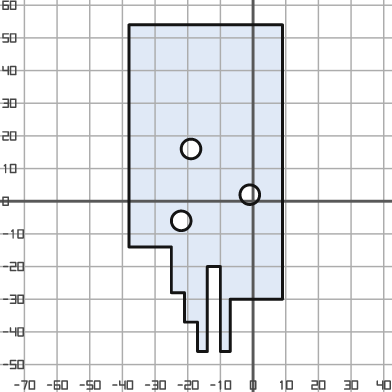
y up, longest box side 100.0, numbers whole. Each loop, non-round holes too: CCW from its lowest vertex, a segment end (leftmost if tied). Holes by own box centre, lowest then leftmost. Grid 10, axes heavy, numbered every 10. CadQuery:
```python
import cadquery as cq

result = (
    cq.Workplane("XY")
    .moveTo(-17.0, -46.0)
    .lineTo(-14.0, -46.0)
    .lineTo(-14.0, -20.0)
    .lineTo(-10.0, -20.0)
    .lineTo(-10.0, -46.0)
    .lineTo(-7.0, -46.0)
    .lineTo(-7.0, -30.0)
    .lineTo(9.0, -30.0)
    .lineTo(9.0, 54.0)
    .lineTo(-38.0, 54.0)
    .lineTo(-38.0, -14.0)
    .lineTo(-25.0, -14.0)
    .lineTo(-25.0, -28.0)
    .lineTo(-21.0, -28.0)
    .lineTo(-21.0, -37.0)
    .lineTo(-17.0, -37.0)
    .close()
    .moveTo(-22.0, -6.0)
    .circle(3.0)
    .moveTo(-1.0, 2.0)
    .circle(3.0)
    .moveTo(-19.0, 16.0)
    .circle(3.0)
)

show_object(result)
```